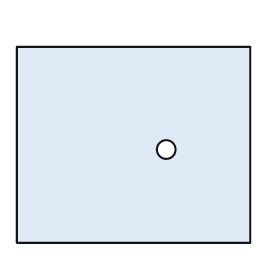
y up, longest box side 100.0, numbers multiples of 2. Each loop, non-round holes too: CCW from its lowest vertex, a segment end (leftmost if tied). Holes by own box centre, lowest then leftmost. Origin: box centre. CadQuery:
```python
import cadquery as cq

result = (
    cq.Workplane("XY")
    .moveTo(-50.0, -42.0)
    .lineTo(50.0, -42.0)
    .lineTo(50.0, 42.0)
    .lineTo(-50.0, 42.0)
    .close()
    .moveTo(14.0, -2.0)
    .circle(4.0)
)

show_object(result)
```